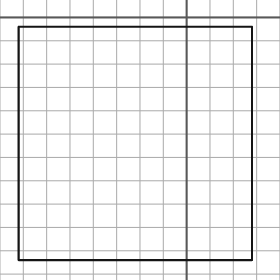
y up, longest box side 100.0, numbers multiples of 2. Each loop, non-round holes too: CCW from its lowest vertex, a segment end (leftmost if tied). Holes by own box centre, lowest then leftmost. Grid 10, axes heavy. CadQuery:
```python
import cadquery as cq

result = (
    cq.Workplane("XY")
    .moveTo(-72.0, -104.0)
    .lineTo(28.0, -104.0)
    .lineTo(28.0, -4.0)
    .lineTo(-72.0, -4.0)
    .close()
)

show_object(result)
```